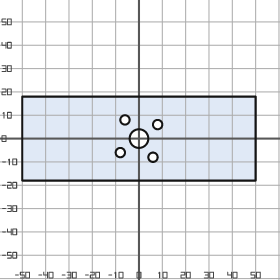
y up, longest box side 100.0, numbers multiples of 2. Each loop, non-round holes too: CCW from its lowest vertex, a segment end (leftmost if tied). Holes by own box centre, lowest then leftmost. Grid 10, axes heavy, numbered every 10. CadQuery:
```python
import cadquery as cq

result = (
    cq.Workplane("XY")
    .moveTo(-50.0, -18.0)
    .lineTo(50.0, -18.0)
    .lineTo(50.0, 18.0)
    .lineTo(-50.0, 18.0)
    .close()
    .moveTo(6.0, -8.0)
    .circle(2.0)
    .moveTo(-8.0, -6.0)
    .circle(2.0)
    .moveTo(0.0, 0.0)
    .circle(4.0)
    .moveTo(8.0, 6.0)
    .circle(2.0)
    .moveTo(-6.0, 8.0)
    .circle(2.0)
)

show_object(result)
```